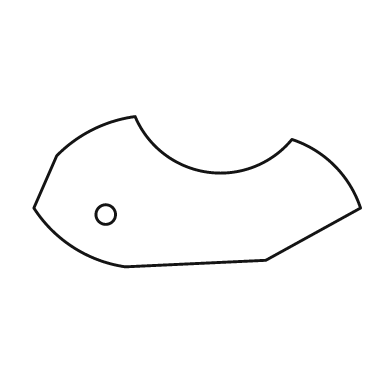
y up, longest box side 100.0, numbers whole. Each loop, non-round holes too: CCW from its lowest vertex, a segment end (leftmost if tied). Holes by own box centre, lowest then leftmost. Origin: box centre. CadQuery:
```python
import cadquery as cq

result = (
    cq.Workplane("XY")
    .moveTo(-22.0, -23.0)
    .lineTo(21.0, -21.0)
    .lineTo(50.0, -5.0)
    .threePointArc((42.0, 8.0), (29.0, 16.0))
    .threePointArc((3.0, 6.0), (-19.0, 23.0))
    .threePointArc((-32.0, 19.0), (-43.0, 11.0))
    .lineTo(-50.0, -5.0)
    .threePointArc((-38.0, -17.0), (-22.0, -23.0))
    .close()
    .moveTo(-28.0, -7.0)
    .circle(3.0)
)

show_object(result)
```